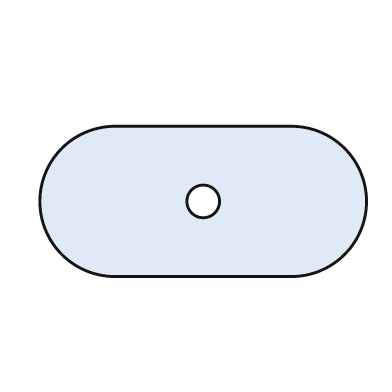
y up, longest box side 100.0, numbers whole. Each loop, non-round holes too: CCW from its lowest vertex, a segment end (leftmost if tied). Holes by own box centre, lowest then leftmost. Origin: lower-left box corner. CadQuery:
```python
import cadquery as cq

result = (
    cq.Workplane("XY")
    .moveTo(23.0, 0.0)
    .lineTo(77.0, 0.0)
    .threePointArc((100.0, 23.0), (77.0, 46.0))
    .lineTo(23.0, 46.0)
    .threePointArc((0.0, 23.0), (23.0, 0.0))
    .close()
    .moveTo(50.0, 23.0)
    .circle(5.0)
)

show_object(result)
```